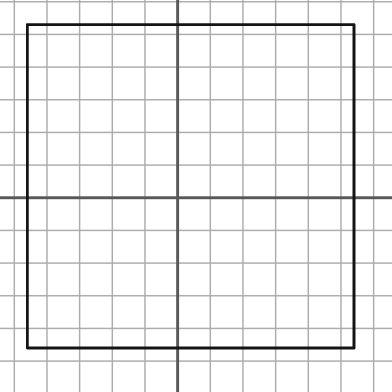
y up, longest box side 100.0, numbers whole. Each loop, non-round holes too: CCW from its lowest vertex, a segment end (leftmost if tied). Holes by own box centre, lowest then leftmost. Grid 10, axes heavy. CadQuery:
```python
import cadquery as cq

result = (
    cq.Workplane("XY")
    .moveTo(-46.0, -46.0)
    .lineTo(54.0, -46.0)
    .lineTo(54.0, 53.0)
    .lineTo(-46.0, 53.0)
    .close()
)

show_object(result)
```